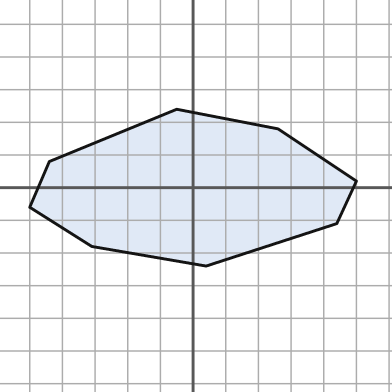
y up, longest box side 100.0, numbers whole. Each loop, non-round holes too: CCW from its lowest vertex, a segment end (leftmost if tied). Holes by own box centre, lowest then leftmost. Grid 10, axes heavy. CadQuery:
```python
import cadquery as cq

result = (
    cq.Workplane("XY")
    .moveTo(4.0, -24.0)
    .lineTo(44.0, -11.0)
    .lineTo(50.0, 2.0)
    .lineTo(26.0, 18.0)
    .lineTo(-5.0, 24.0)
    .lineTo(-44.0, 8.0)
    .lineTo(-50.0, -6.0)
    .lineTo(-31.0, -18.0)
    .close()
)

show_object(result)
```